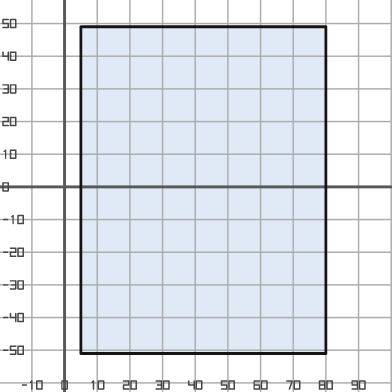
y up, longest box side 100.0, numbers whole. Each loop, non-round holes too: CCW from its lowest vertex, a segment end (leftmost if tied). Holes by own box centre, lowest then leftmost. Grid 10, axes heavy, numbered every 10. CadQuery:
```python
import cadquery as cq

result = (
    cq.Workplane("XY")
    .moveTo(5.0, -51.0)
    .lineTo(80.0, -51.0)
    .lineTo(80.0, 49.0)
    .lineTo(5.0, 49.0)
    .close()
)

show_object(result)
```